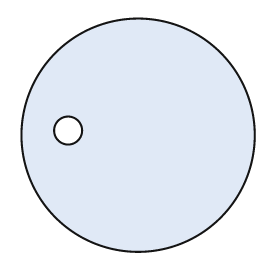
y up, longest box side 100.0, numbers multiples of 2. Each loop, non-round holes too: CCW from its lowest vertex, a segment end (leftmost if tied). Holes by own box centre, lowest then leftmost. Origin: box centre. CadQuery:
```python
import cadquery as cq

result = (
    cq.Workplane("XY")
    .moveTo(0.0, 0.0)
    .circle(50.0)
    .moveTo(-30.0, 2.0)
    .circle(6.0)
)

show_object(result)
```